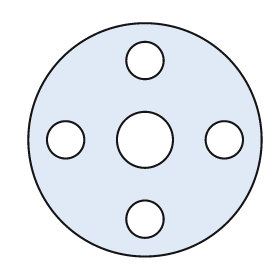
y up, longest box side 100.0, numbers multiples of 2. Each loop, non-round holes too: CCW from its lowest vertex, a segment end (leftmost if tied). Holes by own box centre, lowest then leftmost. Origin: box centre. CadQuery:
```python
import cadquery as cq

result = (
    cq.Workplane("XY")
    .moveTo(0.0, 0.0)
    .circle(50.0)
    .moveTo(0.0, -34.0)
    .circle(8.0)
    .moveTo(-34.0, 0.0)
    .circle(8.0)
    .moveTo(0.0, 0.0)
    .circle(12.0)
    .moveTo(34.0, 0.0)
    .circle(8.0)
    .moveTo(0.0, 34.0)
    .circle(8.0)
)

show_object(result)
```